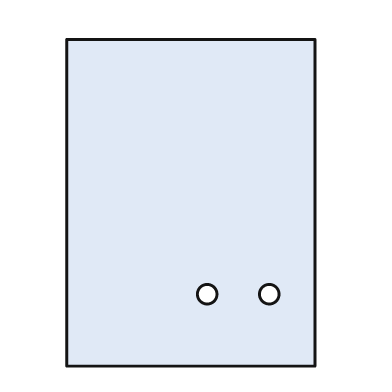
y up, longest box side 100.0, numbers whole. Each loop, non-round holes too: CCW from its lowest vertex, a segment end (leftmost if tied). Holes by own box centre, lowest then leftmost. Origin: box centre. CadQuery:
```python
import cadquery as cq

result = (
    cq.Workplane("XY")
    .moveTo(-38.0, -50.0)
    .lineTo(38.0, -50.0)
    .lineTo(38.0, 50.0)
    .lineTo(-38.0, 50.0)
    .close()
    .moveTo(5.0, -28.0)
    .circle(3.0)
    .moveTo(24.0, -28.0)
    .circle(3.0)
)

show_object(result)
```